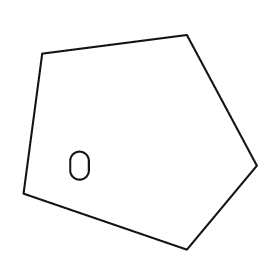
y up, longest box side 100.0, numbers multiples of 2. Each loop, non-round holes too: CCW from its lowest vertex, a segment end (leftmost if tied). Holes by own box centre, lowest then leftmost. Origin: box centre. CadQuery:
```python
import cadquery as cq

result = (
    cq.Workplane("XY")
    .moveTo(20.0, -46.0)
    .lineTo(50.0, -10.0)
    .lineTo(20.0, 46.0)
    .lineTo(-42.0, 38.0)
    .lineTo(-50.0, -22.0)
    .close()
    .moveTo(-30.0, -12.0)
    .threePointArc((-26.0, -16.0), (-22.0, -12.0))
    .lineTo(-22.0, -8.0)
    .threePointArc((-26.0, -4.0), (-30.0, -8.0))
    .close()
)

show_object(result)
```